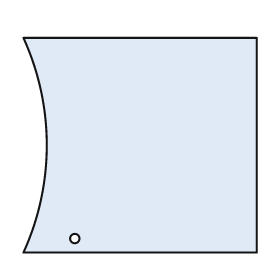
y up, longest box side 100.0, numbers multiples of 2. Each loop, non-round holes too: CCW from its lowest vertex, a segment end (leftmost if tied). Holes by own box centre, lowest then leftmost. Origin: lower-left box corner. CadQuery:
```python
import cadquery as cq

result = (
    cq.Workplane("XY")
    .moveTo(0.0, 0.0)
    .lineTo(100.0, 0.0)
    .lineTo(100.0, 92.0)
    .lineTo(0.0, 92.0)
    .threePointArc((10.0, 46.0), (0.0, 0.0))
    .close()
    .moveTo(22.0, 6.0)
    .circle(2.0)
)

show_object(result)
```